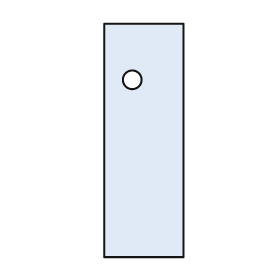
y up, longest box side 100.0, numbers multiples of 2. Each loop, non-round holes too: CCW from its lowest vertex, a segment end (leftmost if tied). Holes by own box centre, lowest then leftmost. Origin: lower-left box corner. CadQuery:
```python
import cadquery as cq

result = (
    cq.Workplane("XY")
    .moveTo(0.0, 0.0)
    .lineTo(34.0, 0.0)
    .lineTo(34.0, 100.0)
    .lineTo(0.0, 100.0)
    .close()
    .moveTo(12.0, 76.0)
    .circle(4.0)
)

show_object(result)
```